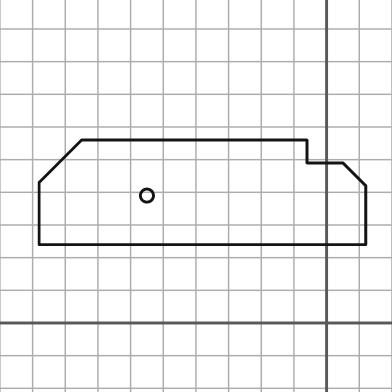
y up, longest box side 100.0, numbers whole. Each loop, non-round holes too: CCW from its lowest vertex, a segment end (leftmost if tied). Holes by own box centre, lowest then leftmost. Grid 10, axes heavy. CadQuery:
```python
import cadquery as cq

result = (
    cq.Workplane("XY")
    .moveTo(-88.0, 24.0)
    .lineTo(12.0, 24.0)
    .lineTo(12.0, 42.0)
    .lineTo(5.0, 49.0)
    .lineTo(-6.0, 49.0)
    .lineTo(-6.0, 56.0)
    .lineTo(-75.0, 56.0)
    .lineTo(-88.0, 43.0)
    .close()
    .moveTo(-55.0, 39.0)
    .circle(2.0)
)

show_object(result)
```